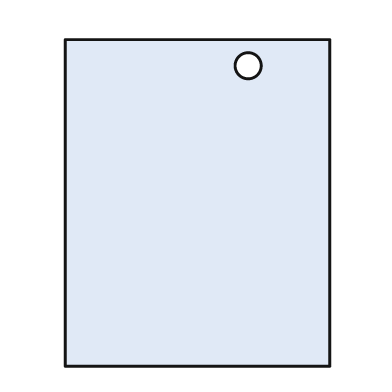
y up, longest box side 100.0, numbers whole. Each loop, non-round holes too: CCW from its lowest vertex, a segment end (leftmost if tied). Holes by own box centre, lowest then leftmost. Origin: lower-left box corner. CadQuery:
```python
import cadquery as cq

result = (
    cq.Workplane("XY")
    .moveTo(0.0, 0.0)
    .lineTo(81.0, 0.0)
    .lineTo(81.0, 100.0)
    .lineTo(0.0, 100.0)
    .close()
    .moveTo(56.0, 92.0)
    .circle(4.0)
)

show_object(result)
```